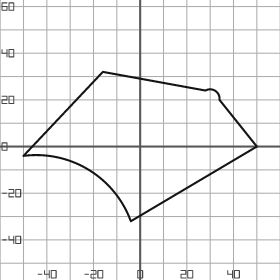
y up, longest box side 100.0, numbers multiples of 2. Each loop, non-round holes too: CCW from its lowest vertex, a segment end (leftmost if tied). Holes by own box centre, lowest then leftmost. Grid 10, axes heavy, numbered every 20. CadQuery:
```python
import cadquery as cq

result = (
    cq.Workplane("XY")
    .moveTo(-4.0, -32.0)
    .lineTo(50.0, 0.0)
    .lineTo(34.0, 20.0)
    .threePointArc((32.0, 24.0), (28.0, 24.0))
    .lineTo(-16.0, 32.0)
    .lineTo(-50.0, -4.0)
    .threePointArc((-22.0, -10.0), (-4.0, -32.0))
    .close()
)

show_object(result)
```